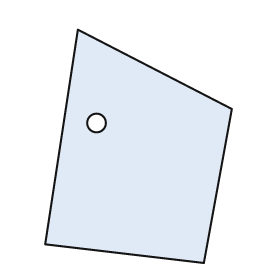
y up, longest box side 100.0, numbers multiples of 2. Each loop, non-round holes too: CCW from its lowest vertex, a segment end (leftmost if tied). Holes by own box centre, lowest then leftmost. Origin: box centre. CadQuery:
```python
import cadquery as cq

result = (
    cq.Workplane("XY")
    .moveTo(28.0, -50.0)
    .lineTo(40.0, 16.0)
    .lineTo(-26.0, 50.0)
    .lineTo(-40.0, -42.0)
    .close()
    .moveTo(-18.0, 10.0)
    .circle(4.0)
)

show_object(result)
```